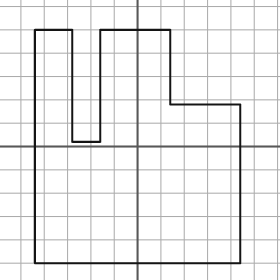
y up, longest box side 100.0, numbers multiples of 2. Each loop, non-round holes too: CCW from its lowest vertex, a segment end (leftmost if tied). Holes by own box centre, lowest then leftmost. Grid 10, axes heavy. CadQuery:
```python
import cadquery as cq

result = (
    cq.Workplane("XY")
    .moveTo(-44.0, -50.0)
    .lineTo(44.0, -50.0)
    .lineTo(44.0, 18.0)
    .lineTo(14.0, 18.0)
    .lineTo(14.0, 50.0)
    .lineTo(-16.0, 50.0)
    .lineTo(-16.0, 2.0)
    .lineTo(-28.0, 2.0)
    .lineTo(-28.0, 50.0)
    .lineTo(-44.0, 50.0)
    .close()
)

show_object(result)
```